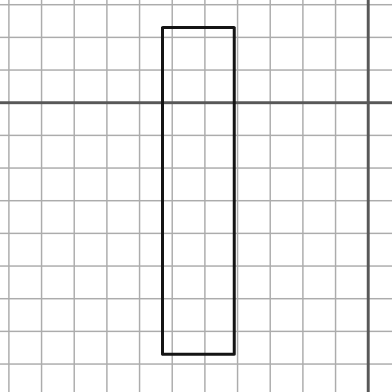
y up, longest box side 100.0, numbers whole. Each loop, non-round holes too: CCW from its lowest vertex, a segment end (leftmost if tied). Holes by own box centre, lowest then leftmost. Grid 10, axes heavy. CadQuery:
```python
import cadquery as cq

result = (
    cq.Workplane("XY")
    .moveTo(-63.0, -77.0)
    .lineTo(-41.0, -77.0)
    .lineTo(-41.0, 23.0)
    .lineTo(-63.0, 23.0)
    .close()
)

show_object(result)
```